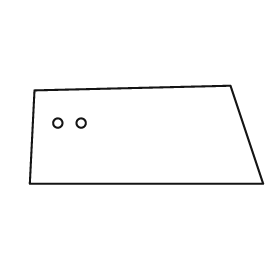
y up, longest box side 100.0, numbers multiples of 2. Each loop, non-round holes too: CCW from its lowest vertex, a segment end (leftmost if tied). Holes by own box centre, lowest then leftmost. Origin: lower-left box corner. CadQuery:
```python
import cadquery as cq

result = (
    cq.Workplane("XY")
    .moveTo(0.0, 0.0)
    .lineTo(100.0, 0.0)
    .lineTo(86.0, 42.0)
    .lineTo(2.0, 40.0)
    .close()
    .moveTo(12.0, 26.0)
    .circle(2.0)
    .moveTo(22.0, 26.0)
    .circle(2.0)
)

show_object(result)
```